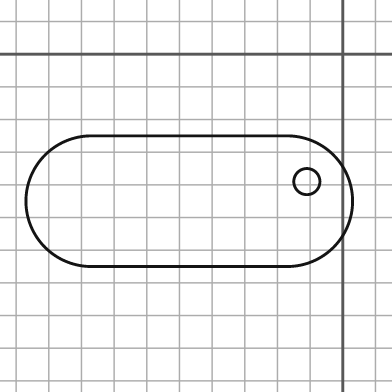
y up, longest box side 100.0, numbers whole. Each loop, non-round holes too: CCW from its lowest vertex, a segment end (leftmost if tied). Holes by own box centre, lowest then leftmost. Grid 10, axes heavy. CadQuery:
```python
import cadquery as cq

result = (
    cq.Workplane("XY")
    .moveTo(-77.0, -65.0)
    .lineTo(-17.0, -65.0)
    .threePointArc((3.0, -45.0), (-17.0, -25.0))
    .lineTo(-77.0, -25.0)
    .threePointArc((-97.0, -45.0), (-77.0, -65.0))
    .close()
    .moveTo(-11.0, -39.0)
    .circle(4.0)
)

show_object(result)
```